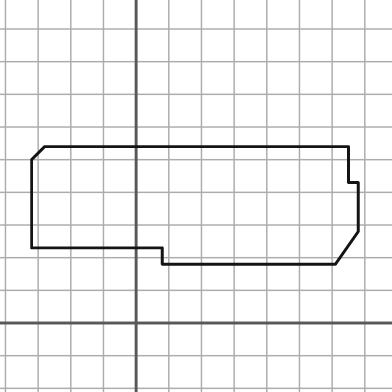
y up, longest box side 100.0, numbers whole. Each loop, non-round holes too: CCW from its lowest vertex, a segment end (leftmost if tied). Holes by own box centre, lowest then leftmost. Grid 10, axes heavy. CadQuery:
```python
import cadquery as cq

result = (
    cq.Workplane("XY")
    .moveTo(8.0, 18.0)
    .lineTo(61.0, 18.0)
    .lineTo(68.0, 28.0)
    .lineTo(68.0, 43.0)
    .lineTo(65.0, 43.0)
    .lineTo(65.0, 54.0)
    .lineTo(-28.0, 54.0)
    .lineTo(-32.0, 50.0)
    .lineTo(-32.0, 23.0)
    .lineTo(8.0, 23.0)
    .close()
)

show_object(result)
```